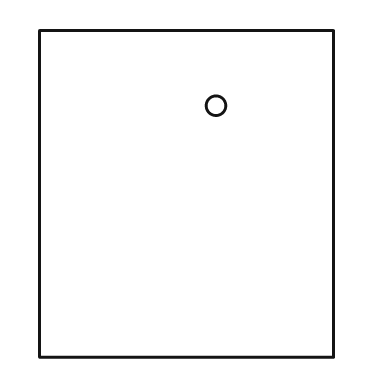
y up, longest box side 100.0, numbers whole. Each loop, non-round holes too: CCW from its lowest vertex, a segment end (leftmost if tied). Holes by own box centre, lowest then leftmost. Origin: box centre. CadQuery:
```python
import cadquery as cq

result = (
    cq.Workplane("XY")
    .moveTo(-45.0, -50.0)
    .lineTo(45.0, -50.0)
    .lineTo(45.0, 50.0)
    .lineTo(-45.0, 50.0)
    .close()
    .moveTo(9.0, 27.0)
    .circle(3.0)
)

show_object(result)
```